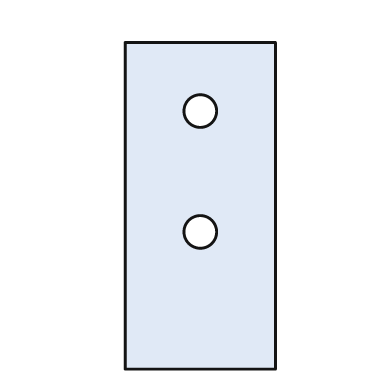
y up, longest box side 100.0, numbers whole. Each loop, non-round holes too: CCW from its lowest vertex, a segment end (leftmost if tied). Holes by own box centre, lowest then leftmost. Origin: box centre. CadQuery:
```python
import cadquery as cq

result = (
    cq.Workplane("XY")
    .moveTo(-23.0, -50.0)
    .lineTo(23.0, -50.0)
    .lineTo(23.0, 50.0)
    .lineTo(-23.0, 50.0)
    .close()
    .moveTo(0.0, -8.0)
    .circle(5.0)
    .moveTo(0.0, 29.0)
    .circle(5.0)
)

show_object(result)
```